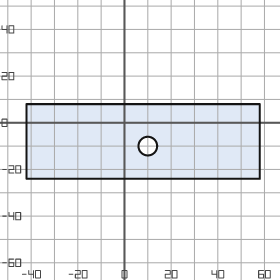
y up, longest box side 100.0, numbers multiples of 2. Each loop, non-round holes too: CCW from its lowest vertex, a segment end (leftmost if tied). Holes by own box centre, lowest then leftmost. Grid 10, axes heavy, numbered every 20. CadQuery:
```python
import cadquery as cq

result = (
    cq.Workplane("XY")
    .moveTo(-42.0, -24.0)
    .lineTo(58.0, -24.0)
    .lineTo(58.0, 8.0)
    .lineTo(-42.0, 8.0)
    .close()
    .moveTo(10.0, -10.0)
    .circle(4.0)
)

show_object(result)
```